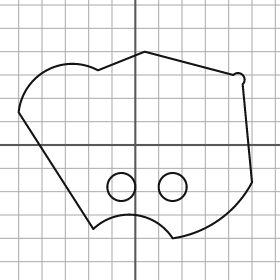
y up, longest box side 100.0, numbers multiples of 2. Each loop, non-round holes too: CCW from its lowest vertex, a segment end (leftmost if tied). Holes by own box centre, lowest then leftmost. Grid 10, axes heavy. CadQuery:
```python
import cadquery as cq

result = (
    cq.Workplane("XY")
    .moveTo(16.0, -40.0)
    .threePointArc((36.0, -32.0), (50.0, -16.0))
    .lineTo(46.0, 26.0)
    .threePointArc((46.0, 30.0), (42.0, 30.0))
    .lineTo(4.0, 40.0)
    .lineTo(-16.0, 32.0)
    .threePointArc((-38.0, 32.0), (-50.0, 14.0))
    .lineTo(-18.0, -36.0)
    .threePointArc((0.0, -30.0), (16.0, -40.0))
    .close()
    .moveTo(-6.0, -18.0)
    .circle(6.0)
    .moveTo(16.0, -18.0)
    .circle(6.0)
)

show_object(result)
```